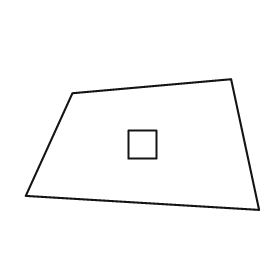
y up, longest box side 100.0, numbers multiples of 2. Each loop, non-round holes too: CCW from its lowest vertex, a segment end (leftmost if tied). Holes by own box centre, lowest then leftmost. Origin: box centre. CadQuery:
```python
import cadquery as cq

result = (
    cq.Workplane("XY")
    .moveTo(50.0, -28.0)
    .lineTo(38.0, 28.0)
    .lineTo(-30.0, 22.0)
    .lineTo(-50.0, -22.0)
    .close()
    .moveTo(-6.0, -6.0)
    .lineTo(6.0, -6.0)
    .lineTo(6.0, 6.0)
    .lineTo(-6.0, 6.0)
    .close()
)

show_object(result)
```